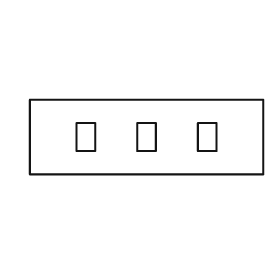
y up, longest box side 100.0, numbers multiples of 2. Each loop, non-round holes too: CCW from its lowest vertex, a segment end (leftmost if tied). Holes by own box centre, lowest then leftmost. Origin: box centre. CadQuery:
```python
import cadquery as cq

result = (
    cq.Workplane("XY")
    .moveTo(-50.0, -16.0)
    .lineTo(50.0, -16.0)
    .lineTo(50.0, 16.0)
    .lineTo(-50.0, 16.0)
    .close()
    .moveTo(-30.0, -6.0)
    .lineTo(-22.0, -6.0)
    .lineTo(-22.0, 6.0)
    .lineTo(-30.0, 6.0)
    .close()
    .moveTo(-4.0, -6.0)
    .lineTo(4.0, -6.0)
    .lineTo(4.0, 6.0)
    .lineTo(-4.0, 6.0)
    .close()
    .moveTo(22.0, -6.0)
    .lineTo(30.0, -6.0)
    .lineTo(30.0, 6.0)
    .lineTo(22.0, 6.0)
    .close()
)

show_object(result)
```